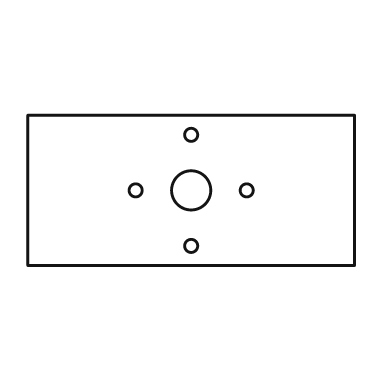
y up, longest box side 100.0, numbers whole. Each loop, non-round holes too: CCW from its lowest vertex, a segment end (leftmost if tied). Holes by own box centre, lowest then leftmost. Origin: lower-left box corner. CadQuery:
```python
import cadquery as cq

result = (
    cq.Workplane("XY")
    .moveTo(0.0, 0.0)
    .lineTo(100.0, 0.0)
    .lineTo(100.0, 46.0)
    .lineTo(0.0, 46.0)
    .close()
    .moveTo(50.0, 6.0)
    .circle(2.0)
    .moveTo(33.0, 23.0)
    .circle(2.0)
    .moveTo(50.0, 23.0)
    .circle(6.0)
    .moveTo(67.0, 23.0)
    .circle(2.0)
    .moveTo(50.0, 40.0)
    .circle(2.0)
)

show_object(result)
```